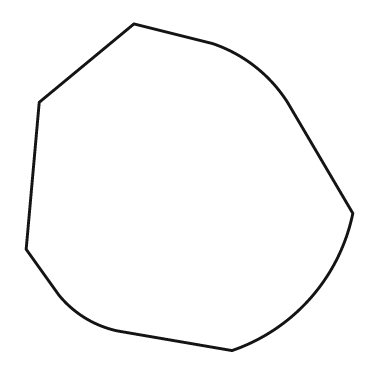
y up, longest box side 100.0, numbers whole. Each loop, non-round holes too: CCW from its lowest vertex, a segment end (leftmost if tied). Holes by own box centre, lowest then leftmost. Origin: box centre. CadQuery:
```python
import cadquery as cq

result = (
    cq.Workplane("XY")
    .moveTo(13.0, -50.0)
    .threePointArc((37.0, -34.0), (50.0, -8.0))
    .lineTo(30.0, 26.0)
    .threePointArc((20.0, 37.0), (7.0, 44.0))
    .lineTo(-17.0, 50.0)
    .lineTo(-46.0, 26.0)
    .lineTo(-50.0, -19.0)
    .lineTo(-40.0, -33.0)
    .threePointArc((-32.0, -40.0), (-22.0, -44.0))
    .close()
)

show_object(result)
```